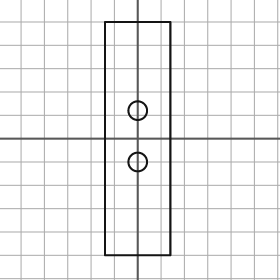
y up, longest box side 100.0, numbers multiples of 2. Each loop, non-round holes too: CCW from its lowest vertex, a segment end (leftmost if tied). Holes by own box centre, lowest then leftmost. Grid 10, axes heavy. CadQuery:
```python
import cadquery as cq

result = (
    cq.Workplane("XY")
    .moveTo(-14.0, -50.0)
    .lineTo(14.0, -50.0)
    .lineTo(14.0, 50.0)
    .lineTo(-14.0, 50.0)
    .close()
    .moveTo(0.0, -10.0)
    .circle(4.0)
    .moveTo(0.0, 12.0)
    .circle(4.0)
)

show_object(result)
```